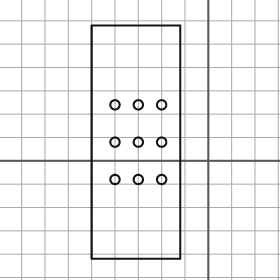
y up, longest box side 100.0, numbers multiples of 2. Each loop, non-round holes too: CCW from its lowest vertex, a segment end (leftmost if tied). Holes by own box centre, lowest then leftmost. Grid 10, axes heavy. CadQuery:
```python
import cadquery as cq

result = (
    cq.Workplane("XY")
    .moveTo(-50.0, -42.0)
    .lineTo(-12.0, -42.0)
    .lineTo(-12.0, 58.0)
    .lineTo(-50.0, 58.0)
    .close()
    .moveTo(-40.0, -8.0)
    .circle(2.0)
    .moveTo(-30.0, -8.0)
    .circle(2.0)
    .moveTo(-20.0, -8.0)
    .circle(2.0)
    .moveTo(-40.0, 8.0)
    .circle(2.0)
    .moveTo(-30.0, 8.0)
    .circle(2.0)
    .moveTo(-20.0, 8.0)
    .circle(2.0)
    .moveTo(-40.0, 24.0)
    .circle(2.0)
    .moveTo(-30.0, 24.0)
    .circle(2.0)
    .moveTo(-20.0, 24.0)
    .circle(2.0)
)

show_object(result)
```